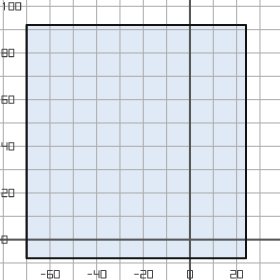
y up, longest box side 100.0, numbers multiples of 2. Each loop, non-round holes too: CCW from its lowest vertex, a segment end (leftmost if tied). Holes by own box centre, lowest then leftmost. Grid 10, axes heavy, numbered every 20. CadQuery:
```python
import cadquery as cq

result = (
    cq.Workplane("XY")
    .moveTo(-70.0, -8.0)
    .lineTo(24.0, -8.0)
    .lineTo(24.0, 92.0)
    .lineTo(-70.0, 92.0)
    .close()
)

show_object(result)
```